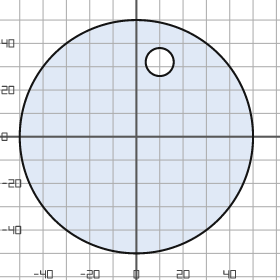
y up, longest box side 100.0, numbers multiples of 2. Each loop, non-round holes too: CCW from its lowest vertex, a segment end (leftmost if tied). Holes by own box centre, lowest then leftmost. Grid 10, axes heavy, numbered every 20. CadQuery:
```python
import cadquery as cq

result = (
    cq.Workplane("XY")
    .moveTo(0.0, 0.0)
    .circle(50.0)
    .moveTo(10.0, 32.0)
    .circle(6.0)
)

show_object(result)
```